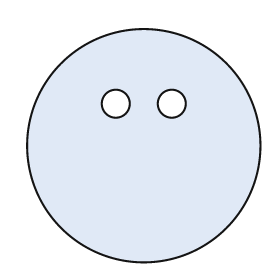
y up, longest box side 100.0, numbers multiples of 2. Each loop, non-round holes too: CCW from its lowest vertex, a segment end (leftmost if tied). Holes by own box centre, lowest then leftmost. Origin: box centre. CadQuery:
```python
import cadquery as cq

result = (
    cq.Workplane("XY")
    .moveTo(0.0, 0.0)
    .circle(50.0)
    .moveTo(-12.0, 18.0)
    .circle(6.0)
    .moveTo(12.0, 18.0)
    .circle(6.0)
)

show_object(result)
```